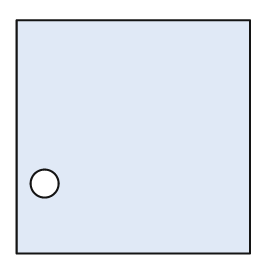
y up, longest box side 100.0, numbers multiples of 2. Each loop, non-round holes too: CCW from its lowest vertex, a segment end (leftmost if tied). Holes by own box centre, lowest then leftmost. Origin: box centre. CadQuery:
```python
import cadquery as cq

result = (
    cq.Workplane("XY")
    .moveTo(-50.0, -50.0)
    .lineTo(50.0, -50.0)
    .lineTo(50.0, 50.0)
    .lineTo(-50.0, 50.0)
    .close()
    .moveTo(-38.0, -20.0)
    .circle(6.0)
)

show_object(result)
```